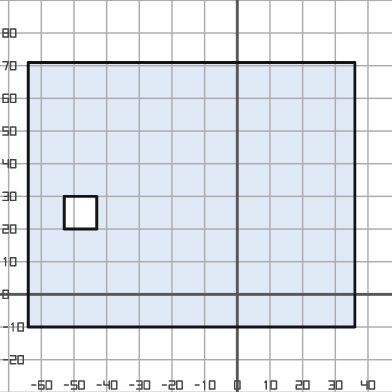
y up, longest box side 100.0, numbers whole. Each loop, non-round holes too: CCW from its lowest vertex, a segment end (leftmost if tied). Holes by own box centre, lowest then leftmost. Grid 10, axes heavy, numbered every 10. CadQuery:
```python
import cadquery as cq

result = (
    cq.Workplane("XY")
    .moveTo(-64.0, -10.0)
    .lineTo(36.0, -10.0)
    .lineTo(36.0, 71.0)
    .lineTo(-64.0, 71.0)
    .close()
    .moveTo(-53.0, 20.0)
    .lineTo(-43.0, 20.0)
    .lineTo(-43.0, 30.0)
    .lineTo(-53.0, 30.0)
    .close()
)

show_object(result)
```